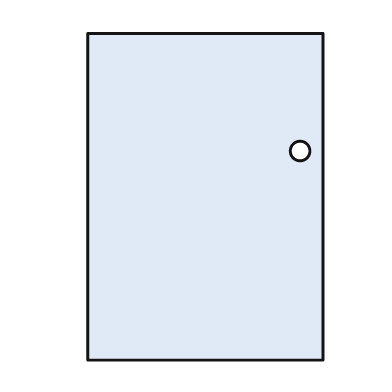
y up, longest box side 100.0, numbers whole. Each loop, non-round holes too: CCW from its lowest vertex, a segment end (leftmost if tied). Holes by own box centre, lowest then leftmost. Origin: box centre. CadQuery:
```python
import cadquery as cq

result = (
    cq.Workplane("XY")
    .moveTo(-36.0, -50.0)
    .lineTo(36.0, -50.0)
    .lineTo(36.0, 50.0)
    .lineTo(-36.0, 50.0)
    .close()
    .moveTo(29.0, 14.0)
    .circle(3.0)
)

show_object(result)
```